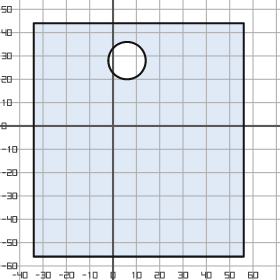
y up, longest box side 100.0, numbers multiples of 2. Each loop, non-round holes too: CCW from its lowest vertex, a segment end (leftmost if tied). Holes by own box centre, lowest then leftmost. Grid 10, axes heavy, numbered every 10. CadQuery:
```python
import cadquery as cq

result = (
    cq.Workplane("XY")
    .moveTo(-34.0, -56.0)
    .lineTo(56.0, -56.0)
    .lineTo(56.0, 44.0)
    .lineTo(-34.0, 44.0)
    .close()
    .moveTo(6.0, 28.0)
    .circle(8.0)
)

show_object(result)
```